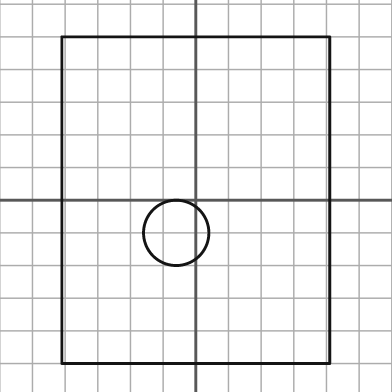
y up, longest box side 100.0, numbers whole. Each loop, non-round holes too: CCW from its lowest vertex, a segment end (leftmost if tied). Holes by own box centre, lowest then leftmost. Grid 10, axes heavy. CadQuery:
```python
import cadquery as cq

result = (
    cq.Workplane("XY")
    .moveTo(-41.0, -50.0)
    .lineTo(41.0, -50.0)
    .lineTo(41.0, 50.0)
    .lineTo(-41.0, 50.0)
    .close()
    .moveTo(-6.0, -10.0)
    .circle(10.0)
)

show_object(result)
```